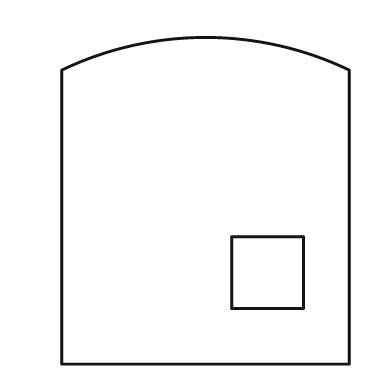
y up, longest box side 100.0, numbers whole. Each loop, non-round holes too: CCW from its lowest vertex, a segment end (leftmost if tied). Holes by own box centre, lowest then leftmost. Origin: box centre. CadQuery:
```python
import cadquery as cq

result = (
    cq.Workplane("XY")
    .moveTo(-44.0, -50.0)
    .lineTo(44.0, -50.0)
    .lineTo(44.0, 40.0)
    .threePointArc((0.0, 50.0), (-44.0, 40.0))
    .close()
    .moveTo(8.0, -33.0)
    .lineTo(30.0, -33.0)
    .lineTo(30.0, -11.0)
    .lineTo(8.0, -11.0)
    .close()
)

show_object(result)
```